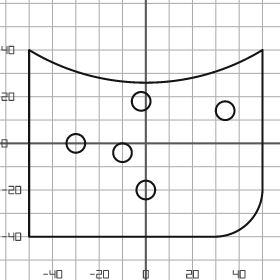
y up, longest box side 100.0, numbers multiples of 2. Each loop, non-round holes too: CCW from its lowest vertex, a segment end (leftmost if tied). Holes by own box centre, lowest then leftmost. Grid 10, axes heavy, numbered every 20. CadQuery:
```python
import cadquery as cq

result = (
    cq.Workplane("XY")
    .moveTo(-50.0, -40.0)
    .lineTo(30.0, -40.0)
    .threePointArc((44.0, -34.0), (50.0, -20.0))
    .lineTo(50.0, 40.0)
    .threePointArc((0.0, 26.0), (-50.0, 40.0))
    .close()
    .moveTo(0.0, -20.0)
    .circle(4.0)
    .moveTo(-10.0, -4.0)
    .circle(4.0)
    .moveTo(-30.0, 0.0)
    .circle(4.0)
    .moveTo(34.0, 14.0)
    .circle(4.0)
    .moveTo(-2.0, 18.0)
    .circle(4.0)
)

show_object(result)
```